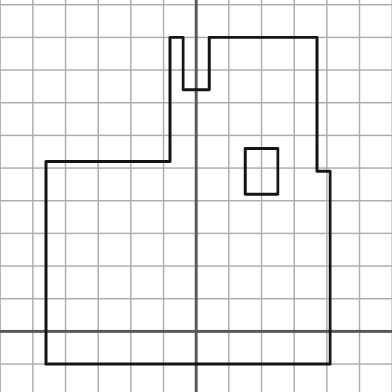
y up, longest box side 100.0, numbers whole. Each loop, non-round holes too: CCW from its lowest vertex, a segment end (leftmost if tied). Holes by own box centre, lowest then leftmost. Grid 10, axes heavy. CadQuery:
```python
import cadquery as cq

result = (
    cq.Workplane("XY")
    .moveTo(-46.0, -10.0)
    .lineTo(41.0, -10.0)
    .lineTo(41.0, 49.0)
    .lineTo(37.0, 49.0)
    .lineTo(37.0, 90.0)
    .lineTo(4.0, 90.0)
    .lineTo(4.0, 74.0)
    .lineTo(-4.0, 74.0)
    .lineTo(-4.0, 90.0)
    .lineTo(-8.0, 90.0)
    .lineTo(-8.0, 52.0)
    .lineTo(-46.0, 52.0)
    .close()
    .moveTo(15.0, 42.0)
    .lineTo(25.0, 42.0)
    .lineTo(25.0, 56.0)
    .lineTo(15.0, 56.0)
    .close()
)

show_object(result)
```